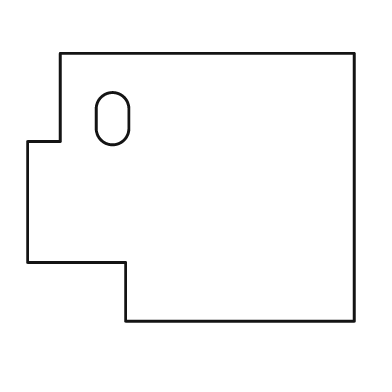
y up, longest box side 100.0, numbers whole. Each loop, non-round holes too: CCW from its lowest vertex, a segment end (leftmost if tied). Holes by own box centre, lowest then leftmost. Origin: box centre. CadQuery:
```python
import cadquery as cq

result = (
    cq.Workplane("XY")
    .moveTo(-20.0, -41.0)
    .lineTo(50.0, -41.0)
    .lineTo(50.0, 41.0)
    .lineTo(-40.0, 41.0)
    .lineTo(-40.0, 14.0)
    .lineTo(-50.0, 14.0)
    .lineTo(-50.0, -23.0)
    .lineTo(-20.0, -23.0)
    .close()
    .moveTo(-29.0, 18.0)
    .threePointArc((-24.0, 13.0), (-19.0, 18.0))
    .lineTo(-19.0, 24.0)
    .threePointArc((-24.0, 29.0), (-29.0, 24.0))
    .close()
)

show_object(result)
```